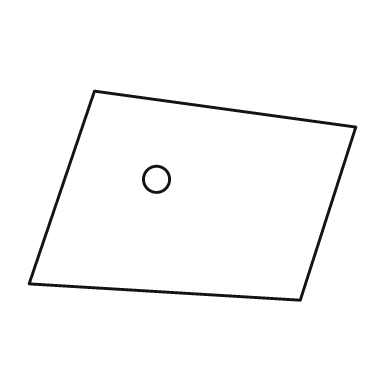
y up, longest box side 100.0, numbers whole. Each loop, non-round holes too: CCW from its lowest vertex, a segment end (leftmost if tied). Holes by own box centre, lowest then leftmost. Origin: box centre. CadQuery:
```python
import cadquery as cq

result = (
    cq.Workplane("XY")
    .moveTo(33.0, -32.0)
    .lineTo(50.0, 21.0)
    .lineTo(-30.0, 32.0)
    .lineTo(-50.0, -27.0)
    .close()
    .moveTo(-11.0, 5.0)
    .circle(4.0)
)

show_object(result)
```